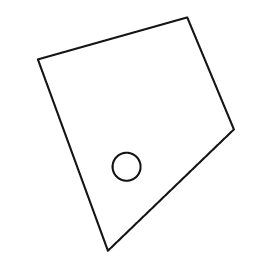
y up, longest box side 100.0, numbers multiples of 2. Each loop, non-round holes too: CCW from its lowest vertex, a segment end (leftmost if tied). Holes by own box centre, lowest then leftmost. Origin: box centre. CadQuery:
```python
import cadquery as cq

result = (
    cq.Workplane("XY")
    .moveTo(-12.0, -50.0)
    .lineTo(42.0, 2.0)
    .lineTo(22.0, 50.0)
    .lineTo(-42.0, 32.0)
    .close()
    .moveTo(-4.0, -14.0)
    .circle(6.0)
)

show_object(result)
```